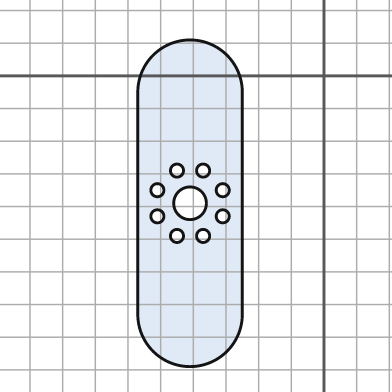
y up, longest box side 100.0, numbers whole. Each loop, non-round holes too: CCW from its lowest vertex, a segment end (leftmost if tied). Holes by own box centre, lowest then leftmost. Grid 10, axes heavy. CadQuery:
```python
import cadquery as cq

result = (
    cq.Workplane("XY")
    .moveTo(-57.0, -73.0)
    .threePointArc((-41.0, -89.0), (-25.0, -73.0))
    .lineTo(-25.0, -5.0)
    .threePointArc((-41.0, 11.0), (-57.0, -5.0))
    .close()
    .moveTo(-45.0, -49.0)
    .circle(2.0)
    .moveTo(-37.0, -49.0)
    .circle(2.0)
    .moveTo(-51.0, -43.0)
    .circle(2.0)
    .moveTo(-31.0, -43.0)
    .circle(2.0)
    .moveTo(-41.0, -39.0)
    .circle(5.0)
    .moveTo(-51.0, -35.0)
    .circle(2.0)
    .moveTo(-31.0, -35.0)
    .circle(2.0)
    .moveTo(-45.0, -29.0)
    .circle(2.0)
    .moveTo(-37.0, -29.0)
    .circle(2.0)
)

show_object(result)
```